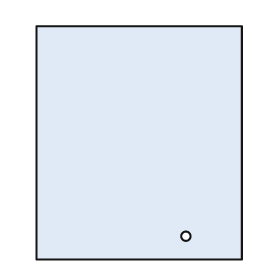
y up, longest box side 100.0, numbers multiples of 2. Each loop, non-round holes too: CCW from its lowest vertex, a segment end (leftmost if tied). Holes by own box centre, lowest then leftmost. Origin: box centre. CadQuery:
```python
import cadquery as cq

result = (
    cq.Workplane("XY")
    .moveTo(-44.0, -50.0)
    .lineTo(44.0, -50.0)
    .lineTo(44.0, 50.0)
    .lineTo(-44.0, 50.0)
    .close()
    .moveTo(20.0, -40.0)
    .circle(2.0)
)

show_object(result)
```